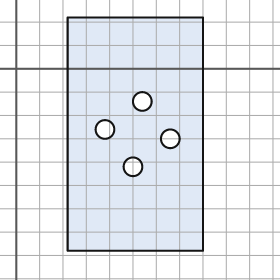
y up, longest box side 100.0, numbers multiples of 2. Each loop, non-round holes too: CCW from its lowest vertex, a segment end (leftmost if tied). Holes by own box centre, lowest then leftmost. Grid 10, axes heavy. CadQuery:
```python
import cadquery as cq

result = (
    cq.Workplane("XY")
    .moveTo(22.0, -78.0)
    .lineTo(80.0, -78.0)
    .lineTo(80.0, 22.0)
    .lineTo(22.0, 22.0)
    .close()
    .moveTo(50.0, -42.0)
    .circle(4.0)
    .moveTo(66.0, -30.0)
    .circle(4.0)
    .moveTo(38.0, -26.0)
    .circle(4.0)
    .moveTo(54.0, -14.0)
    .circle(4.0)
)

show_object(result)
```